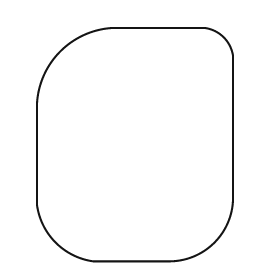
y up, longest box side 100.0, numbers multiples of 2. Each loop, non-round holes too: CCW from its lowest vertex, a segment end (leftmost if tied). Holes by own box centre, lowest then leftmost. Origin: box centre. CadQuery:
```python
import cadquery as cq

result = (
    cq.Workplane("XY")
    .moveTo(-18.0, -50.0)
    .lineTo(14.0, -50.0)
    .threePointArc((34.0, -42.0), (42.0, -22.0))
    .lineTo(42.0, 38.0)
    .threePointArc((38.0, 46.0), (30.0, 50.0))
    .lineTo(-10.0, 50.0)
    .threePointArc((-32.0, 40.0), (-42.0, 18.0))
    .lineTo(-42.0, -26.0)
    .threePointArc((-34.0, -42.0), (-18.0, -50.0))
    .close()
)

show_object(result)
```